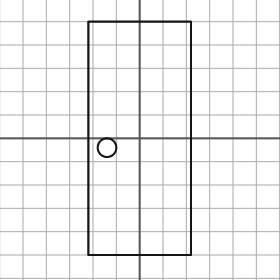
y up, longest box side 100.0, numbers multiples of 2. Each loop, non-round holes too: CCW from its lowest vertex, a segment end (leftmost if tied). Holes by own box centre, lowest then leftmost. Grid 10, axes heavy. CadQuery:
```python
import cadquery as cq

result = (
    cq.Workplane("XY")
    .moveTo(-22.0, -50.0)
    .lineTo(22.0, -50.0)
    .lineTo(22.0, 50.0)
    .lineTo(-22.0, 50.0)
    .close()
    .moveTo(-14.0, -4.0)
    .circle(4.0)
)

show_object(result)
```